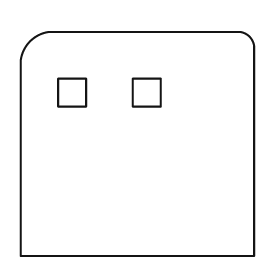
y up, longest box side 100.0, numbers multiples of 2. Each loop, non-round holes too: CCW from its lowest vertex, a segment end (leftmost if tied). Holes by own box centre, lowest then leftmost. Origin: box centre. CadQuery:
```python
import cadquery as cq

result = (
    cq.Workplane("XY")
    .moveTo(-50.0, -48.0)
    .lineTo(50.0, -48.0)
    .lineTo(50.0, 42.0)
    .threePointArc((48.0, 46.0), (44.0, 48.0))
    .lineTo(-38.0, 48.0)
    .threePointArc((-46.0, 44.0), (-50.0, 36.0))
    .close()
    .moveTo(-34.0, 16.0)
    .lineTo(-22.0, 16.0)
    .lineTo(-22.0, 28.0)
    .lineTo(-34.0, 28.0)
    .close()
    .moveTo(-2.0, 16.0)
    .lineTo(10.0, 16.0)
    .lineTo(10.0, 28.0)
    .lineTo(-2.0, 28.0)
    .close()
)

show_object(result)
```